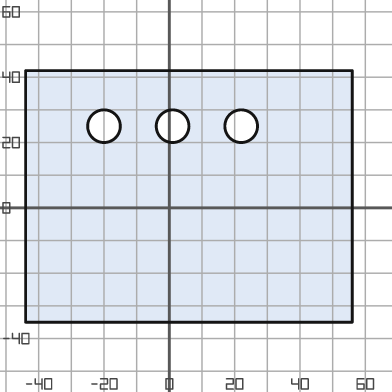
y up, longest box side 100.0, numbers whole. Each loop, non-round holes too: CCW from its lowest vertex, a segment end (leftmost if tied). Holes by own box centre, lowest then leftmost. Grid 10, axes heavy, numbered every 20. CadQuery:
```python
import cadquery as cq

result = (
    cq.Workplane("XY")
    .moveTo(-44.0, -35.0)
    .lineTo(56.0, -35.0)
    .lineTo(56.0, 42.0)
    .lineTo(-44.0, 42.0)
    .close()
    .moveTo(-20.0, 25.0)
    .circle(5.0)
    .moveTo(1.0, 25.0)
    .circle(5.0)
    .moveTo(22.0, 25.0)
    .circle(5.0)
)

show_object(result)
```